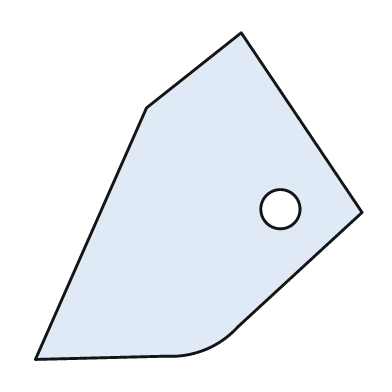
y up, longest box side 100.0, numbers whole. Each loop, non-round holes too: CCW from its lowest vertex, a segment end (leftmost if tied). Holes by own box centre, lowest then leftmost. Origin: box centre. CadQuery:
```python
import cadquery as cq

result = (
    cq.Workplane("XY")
    .moveTo(-50.0, -50.0)
    .lineTo(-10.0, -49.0)
    .threePointArc((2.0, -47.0), (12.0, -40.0))
    .lineTo(50.0, -5.0)
    .lineTo(13.0, 50.0)
    .lineTo(-16.0, 27.0)
    .close()
    .moveTo(25.0, -4.0)
    .circle(6.0)
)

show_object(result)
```